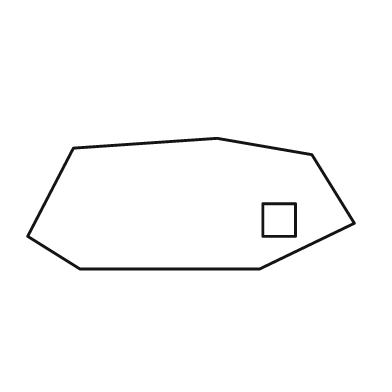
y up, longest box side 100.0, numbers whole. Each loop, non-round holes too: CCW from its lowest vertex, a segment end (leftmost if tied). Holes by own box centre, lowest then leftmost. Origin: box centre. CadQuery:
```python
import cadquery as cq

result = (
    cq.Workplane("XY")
    .moveTo(-34.0, -20.0)
    .lineTo(21.0, -20.0)
    .lineTo(50.0, -6.0)
    .lineTo(37.0, 15.0)
    .lineTo(8.0, 20.0)
    .lineTo(-36.0, 17.0)
    .lineTo(-50.0, -10.0)
    .close()
    .moveTo(22.0, -10.0)
    .lineTo(32.0, -10.0)
    .lineTo(32.0, 0.0)
    .lineTo(22.0, 0.0)
    .close()
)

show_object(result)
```